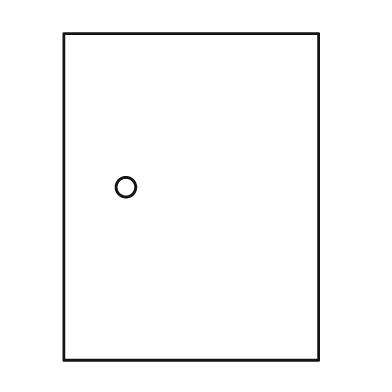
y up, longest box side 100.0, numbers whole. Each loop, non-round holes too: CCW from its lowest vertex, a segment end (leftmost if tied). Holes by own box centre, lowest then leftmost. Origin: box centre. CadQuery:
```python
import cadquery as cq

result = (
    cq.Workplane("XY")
    .moveTo(-39.0, -50.0)
    .lineTo(39.0, -50.0)
    .lineTo(39.0, 50.0)
    .lineTo(-39.0, 50.0)
    .close()
    .moveTo(-20.0, 3.0)
    .circle(3.0)
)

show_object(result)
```